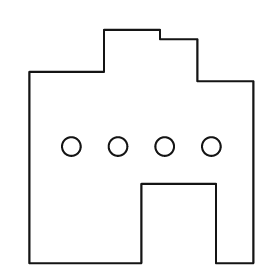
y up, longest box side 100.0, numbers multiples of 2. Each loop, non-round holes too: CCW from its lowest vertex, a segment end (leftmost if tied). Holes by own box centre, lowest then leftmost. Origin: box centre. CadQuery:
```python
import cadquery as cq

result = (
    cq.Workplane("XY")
    .moveTo(-48.0, -50.0)
    .lineTo(0.0, -50.0)
    .lineTo(0.0, -16.0)
    .lineTo(32.0, -16.0)
    .lineTo(32.0, -50.0)
    .lineTo(48.0, -50.0)
    .lineTo(48.0, 28.0)
    .lineTo(24.0, 28.0)
    .lineTo(24.0, 46.0)
    .lineTo(8.0, 46.0)
    .lineTo(8.0, 50.0)
    .lineTo(-16.0, 50.0)
    .lineTo(-16.0, 32.0)
    .lineTo(-48.0, 32.0)
    .close()
    .moveTo(-30.0, 0.0)
    .circle(4.0)
    .moveTo(-10.0, 0.0)
    .circle(4.0)
    .moveTo(10.0, 0.0)
    .circle(4.0)
    .moveTo(30.0, 0.0)
    .circle(4.0)
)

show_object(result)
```